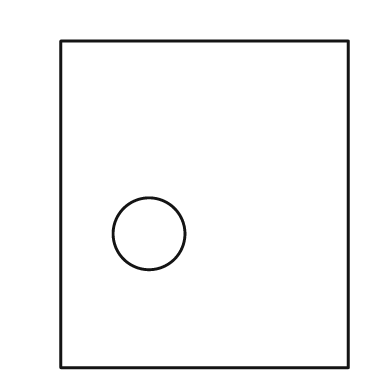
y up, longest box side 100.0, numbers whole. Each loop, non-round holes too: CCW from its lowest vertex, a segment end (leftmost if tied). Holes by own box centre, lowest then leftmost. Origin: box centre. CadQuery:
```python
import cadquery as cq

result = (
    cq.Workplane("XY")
    .moveTo(-44.0, -50.0)
    .lineTo(44.0, -50.0)
    .lineTo(44.0, 50.0)
    .lineTo(-44.0, 50.0)
    .close()
    .moveTo(-17.0, -9.0)
    .circle(11.0)
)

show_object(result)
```